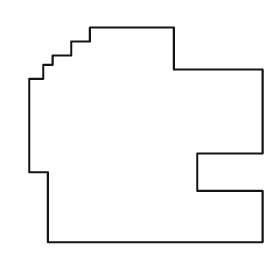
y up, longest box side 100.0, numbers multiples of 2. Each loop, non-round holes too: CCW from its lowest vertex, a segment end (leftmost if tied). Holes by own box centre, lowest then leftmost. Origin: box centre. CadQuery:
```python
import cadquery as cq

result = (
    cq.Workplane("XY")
    .moveTo(-42.0, -46.0)
    .lineTo(50.0, -46.0)
    .lineTo(50.0, -24.0)
    .lineTo(22.0, -24.0)
    .lineTo(22.0, -8.0)
    .lineTo(50.0, -8.0)
    .lineTo(50.0, 28.0)
    .lineTo(12.0, 28.0)
    .lineTo(12.0, 46.0)
    .lineTo(-24.0, 46.0)
    .lineTo(-24.0, 40.0)
    .lineTo(-32.0, 40.0)
    .lineTo(-32.0, 34.0)
    .lineTo(-40.0, 34.0)
    .lineTo(-40.0, 30.0)
    .lineTo(-44.0, 30.0)
    .lineTo(-44.0, 24.0)
    .lineTo(-50.0, 24.0)
    .lineTo(-50.0, -16.0)
    .lineTo(-42.0, -16.0)
    .close()
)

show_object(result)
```